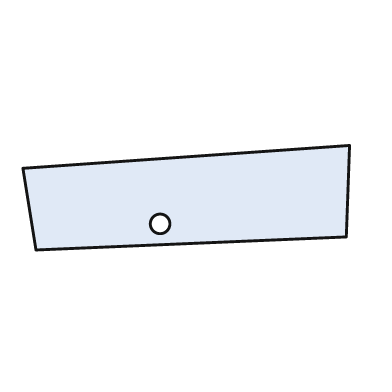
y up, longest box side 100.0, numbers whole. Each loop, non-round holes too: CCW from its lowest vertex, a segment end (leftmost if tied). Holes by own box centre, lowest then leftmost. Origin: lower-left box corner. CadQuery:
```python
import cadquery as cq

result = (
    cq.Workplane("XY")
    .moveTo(4.0, 0.0)
    .lineTo(99.0, 4.0)
    .lineTo(100.0, 32.0)
    .lineTo(0.0, 25.0)
    .close()
    .moveTo(42.0, 8.0)
    .circle(3.0)
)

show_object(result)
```